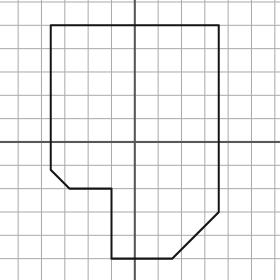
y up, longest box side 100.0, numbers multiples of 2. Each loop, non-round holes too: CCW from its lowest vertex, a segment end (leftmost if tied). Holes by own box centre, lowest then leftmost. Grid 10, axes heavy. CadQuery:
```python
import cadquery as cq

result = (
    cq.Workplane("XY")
    .moveTo(-10.0, -50.0)
    .lineTo(16.0, -50.0)
    .lineTo(36.0, -30.0)
    .lineTo(36.0, 50.0)
    .lineTo(-36.0, 50.0)
    .lineTo(-36.0, -12.0)
    .lineTo(-28.0, -20.0)
    .lineTo(-10.0, -20.0)
    .close()
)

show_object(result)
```